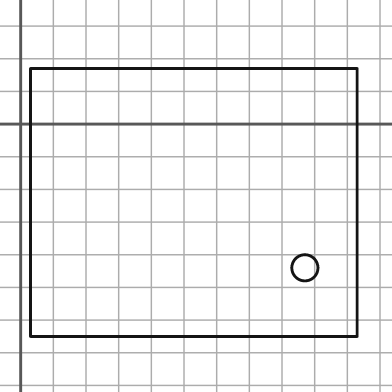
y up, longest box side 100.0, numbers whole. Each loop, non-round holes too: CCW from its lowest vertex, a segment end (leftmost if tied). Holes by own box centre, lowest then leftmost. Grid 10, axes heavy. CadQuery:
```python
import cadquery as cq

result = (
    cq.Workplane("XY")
    .moveTo(3.0, -65.0)
    .lineTo(103.0, -65.0)
    .lineTo(103.0, 17.0)
    .lineTo(3.0, 17.0)
    .close()
    .moveTo(87.0, -44.0)
    .circle(4.0)
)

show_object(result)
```